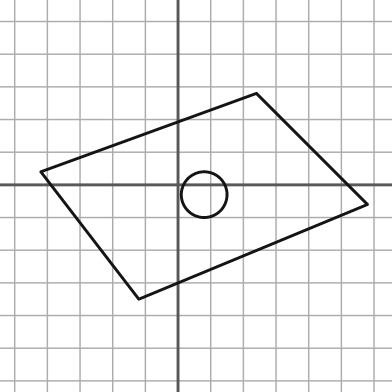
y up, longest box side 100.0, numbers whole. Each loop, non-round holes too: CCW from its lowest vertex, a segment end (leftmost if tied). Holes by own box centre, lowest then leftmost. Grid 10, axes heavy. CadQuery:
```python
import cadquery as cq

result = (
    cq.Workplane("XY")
    .moveTo(-12.0, -35.0)
    .lineTo(58.0, -6.0)
    .lineTo(24.0, 28.0)
    .lineTo(-42.0, 4.0)
    .close()
    .moveTo(8.0, -3.0)
    .circle(7.0)
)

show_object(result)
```